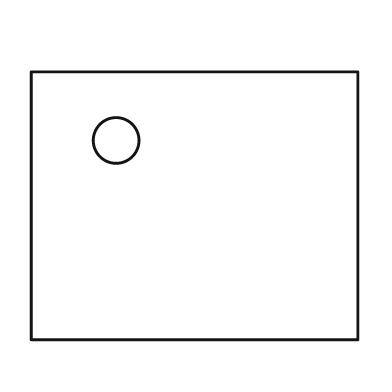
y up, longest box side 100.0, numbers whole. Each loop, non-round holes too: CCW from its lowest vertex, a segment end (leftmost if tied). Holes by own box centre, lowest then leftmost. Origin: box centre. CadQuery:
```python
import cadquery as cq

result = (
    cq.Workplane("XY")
    .moveTo(-50.0, -41.0)
    .lineTo(50.0, -41.0)
    .lineTo(50.0, 41.0)
    .lineTo(-50.0, 41.0)
    .close()
    .moveTo(-24.0, 20.0)
    .circle(7.0)
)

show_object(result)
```